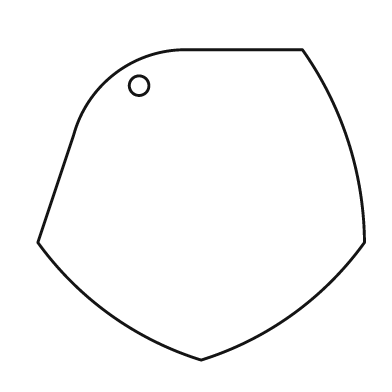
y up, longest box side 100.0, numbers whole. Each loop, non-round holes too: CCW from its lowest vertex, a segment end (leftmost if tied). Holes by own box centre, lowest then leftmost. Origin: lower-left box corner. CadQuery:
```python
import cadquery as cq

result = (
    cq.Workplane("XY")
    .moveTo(50.0, 0.0)
    .threePointArc((78.0, 14.0), (100.0, 36.0))
    .threePointArc((95.0, 67.0), (81.0, 95.0))
    .lineTo(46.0, 95.0)
    .threePointArc((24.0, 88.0), (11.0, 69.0))
    .lineTo(0.0, 36.0)
    .threePointArc((22.0, 14.0), (50.0, 0.0))
    .close()
    .moveTo(31.0, 84.0)
    .circle(3.0)
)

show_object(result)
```